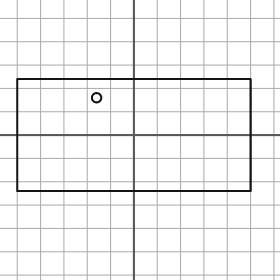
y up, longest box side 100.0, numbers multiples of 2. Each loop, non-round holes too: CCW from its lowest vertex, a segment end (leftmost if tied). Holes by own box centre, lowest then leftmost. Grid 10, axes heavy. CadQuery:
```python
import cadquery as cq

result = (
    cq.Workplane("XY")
    .moveTo(-50.0, -24.0)
    .lineTo(50.0, -24.0)
    .lineTo(50.0, 24.0)
    .lineTo(-50.0, 24.0)
    .close()
    .moveTo(-16.0, 16.0)
    .circle(2.0)
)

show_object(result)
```